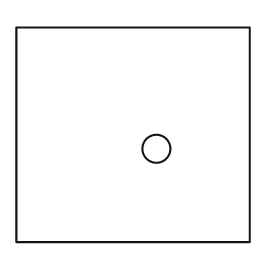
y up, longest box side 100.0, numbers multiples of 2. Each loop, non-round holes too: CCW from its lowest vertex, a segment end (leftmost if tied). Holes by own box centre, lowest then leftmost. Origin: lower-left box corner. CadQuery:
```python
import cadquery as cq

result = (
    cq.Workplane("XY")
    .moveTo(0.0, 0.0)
    .lineTo(100.0, 0.0)
    .lineTo(100.0, 92.0)
    .lineTo(0.0, 92.0)
    .close()
    .moveTo(60.0, 40.0)
    .circle(6.0)
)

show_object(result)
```